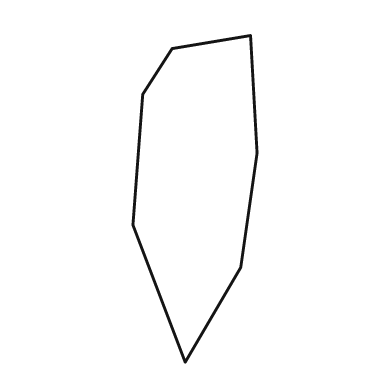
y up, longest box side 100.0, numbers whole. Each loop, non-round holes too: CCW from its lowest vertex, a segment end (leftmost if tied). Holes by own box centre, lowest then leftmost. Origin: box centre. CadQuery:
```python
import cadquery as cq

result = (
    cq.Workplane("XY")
    .moveTo(-3.0, -50.0)
    .lineTo(14.0, -21.0)
    .lineTo(19.0, 14.0)
    .lineTo(17.0, 50.0)
    .lineTo(-7.0, 46.0)
    .lineTo(-16.0, 32.0)
    .lineTo(-19.0, -8.0)
    .close()
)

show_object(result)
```